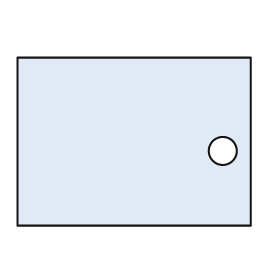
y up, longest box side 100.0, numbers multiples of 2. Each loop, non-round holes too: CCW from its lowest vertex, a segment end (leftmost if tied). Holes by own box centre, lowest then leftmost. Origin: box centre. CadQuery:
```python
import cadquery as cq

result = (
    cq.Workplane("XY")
    .moveTo(-50.0, -36.0)
    .lineTo(50.0, -36.0)
    .lineTo(50.0, 36.0)
    .lineTo(-50.0, 36.0)
    .close()
    .moveTo(38.0, -4.0)
    .circle(6.0)
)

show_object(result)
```